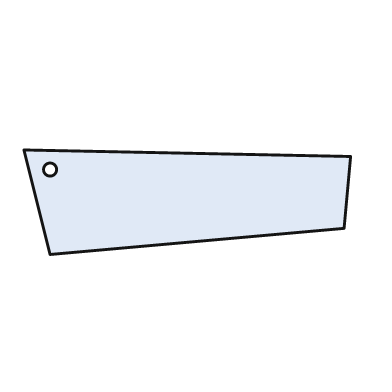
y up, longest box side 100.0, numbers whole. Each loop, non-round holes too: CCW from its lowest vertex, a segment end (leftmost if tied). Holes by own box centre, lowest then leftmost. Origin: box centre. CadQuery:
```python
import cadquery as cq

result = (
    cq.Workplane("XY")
    .moveTo(-42.0, -16.0)
    .lineTo(48.0, -8.0)
    .lineTo(50.0, 14.0)
    .lineTo(-50.0, 16.0)
    .close()
    .moveTo(-42.0, 10.0)
    .circle(2.0)
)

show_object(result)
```